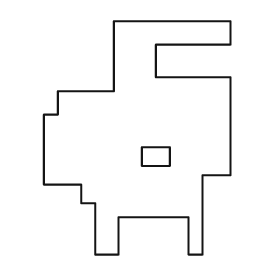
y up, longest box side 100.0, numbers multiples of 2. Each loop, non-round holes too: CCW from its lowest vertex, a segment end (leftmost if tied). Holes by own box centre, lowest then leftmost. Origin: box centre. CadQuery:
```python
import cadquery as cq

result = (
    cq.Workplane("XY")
    .moveTo(-18.0, -50.0)
    .lineTo(-8.0, -50.0)
    .lineTo(-8.0, -34.0)
    .lineTo(22.0, -34.0)
    .lineTo(22.0, -50.0)
    .lineTo(28.0, -50.0)
    .lineTo(28.0, -16.0)
    .lineTo(40.0, -16.0)
    .lineTo(40.0, 26.0)
    .lineTo(8.0, 26.0)
    .lineTo(8.0, 40.0)
    .lineTo(40.0, 40.0)
    .lineTo(40.0, 50.0)
    .lineTo(-10.0, 50.0)
    .lineTo(-10.0, 20.0)
    .lineTo(-34.0, 20.0)
    .lineTo(-34.0, 10.0)
    .lineTo(-40.0, 10.0)
    .lineTo(-40.0, -20.0)
    .lineTo(-24.0, -20.0)
    .lineTo(-24.0, -28.0)
    .lineTo(-18.0, -28.0)
    .close()
    .moveTo(2.0, -12.0)
    .lineTo(14.0, -12.0)
    .lineTo(14.0, -4.0)
    .lineTo(2.0, -4.0)
    .close()
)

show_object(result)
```